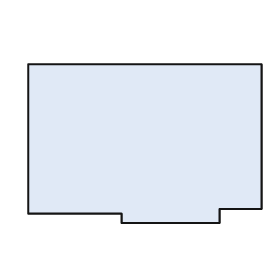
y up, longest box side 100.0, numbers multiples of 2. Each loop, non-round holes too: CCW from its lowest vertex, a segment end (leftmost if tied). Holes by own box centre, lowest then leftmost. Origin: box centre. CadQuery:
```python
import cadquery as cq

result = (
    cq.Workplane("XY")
    .moveTo(-10.0, -34.0)
    .lineTo(32.0, -34.0)
    .lineTo(32.0, -28.0)
    .lineTo(50.0, -28.0)
    .lineTo(50.0, 34.0)
    .lineTo(-50.0, 34.0)
    .lineTo(-50.0, -30.0)
    .lineTo(-10.0, -30.0)
    .close()
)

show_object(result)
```